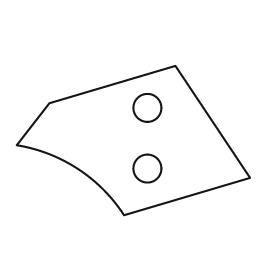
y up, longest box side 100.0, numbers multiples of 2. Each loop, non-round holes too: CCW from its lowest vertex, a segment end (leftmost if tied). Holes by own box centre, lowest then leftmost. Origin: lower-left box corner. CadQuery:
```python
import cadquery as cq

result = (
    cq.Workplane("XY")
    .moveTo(46.0, 0.0)
    .lineTo(100.0, 16.0)
    .lineTo(68.0, 64.0)
    .lineTo(14.0, 48.0)
    .lineTo(0.0, 30.0)
    .threePointArc((26.0, 20.0), (46.0, 0.0))
    .close()
    .moveTo(56.0, 20.0)
    .circle(6.0)
    .moveTo(56.0, 46.0)
    .circle(6.0)
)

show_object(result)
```